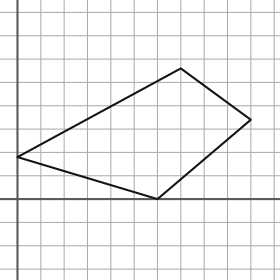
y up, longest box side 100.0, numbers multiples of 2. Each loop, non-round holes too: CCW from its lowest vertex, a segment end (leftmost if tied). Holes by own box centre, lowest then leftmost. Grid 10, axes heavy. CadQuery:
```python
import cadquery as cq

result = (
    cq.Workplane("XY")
    .moveTo(60.0, 0.0)
    .lineTo(100.0, 34.0)
    .lineTo(70.0, 56.0)
    .lineTo(0.0, 18.0)
    .close()
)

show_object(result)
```